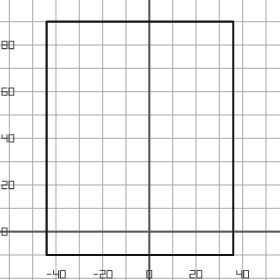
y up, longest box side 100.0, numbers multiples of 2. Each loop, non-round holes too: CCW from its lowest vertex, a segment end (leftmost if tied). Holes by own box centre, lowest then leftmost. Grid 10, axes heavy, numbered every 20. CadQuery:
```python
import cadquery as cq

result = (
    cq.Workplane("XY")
    .moveTo(-44.0, -10.0)
    .lineTo(36.0, -10.0)
    .lineTo(36.0, 90.0)
    .lineTo(-44.0, 90.0)
    .close()
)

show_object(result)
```